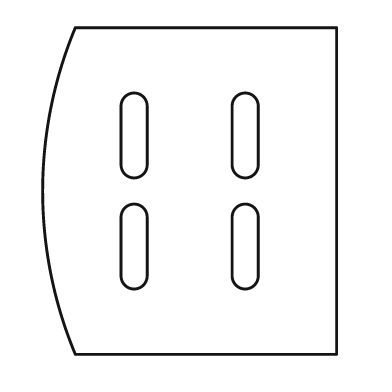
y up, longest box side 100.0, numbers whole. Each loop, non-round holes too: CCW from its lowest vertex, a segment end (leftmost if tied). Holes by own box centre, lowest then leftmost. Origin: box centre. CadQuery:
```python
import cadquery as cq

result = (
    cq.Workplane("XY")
    .moveTo(-35.0, -50.0)
    .lineTo(45.0, -50.0)
    .lineTo(45.0, 50.0)
    .lineTo(-35.0, 50.0)
    .threePointArc((-45.0, 0.0), (-35.0, -50.0))
    .close()
    .moveTo(-21.0, -26.0)
    .threePointArc((-17.0, -30.0), (-13.0, -26.0))
    .lineTo(-13.0, -8.0)
    .threePointArc((-17.0, -4.0), (-21.0, -8.0))
    .close()
    .moveTo(13.0, -26.0)
    .threePointArc((17.0, -30.0), (21.0, -26.0))
    .lineTo(21.0, -8.0)
    .threePointArc((17.0, -4.0), (13.0, -8.0))
    .close()
    .moveTo(-21.0, 8.0)
    .threePointArc((-17.0, 4.0), (-13.0, 8.0))
    .lineTo(-13.0, 26.0)
    .threePointArc((-17.0, 30.0), (-21.0, 26.0))
    .close()
    .moveTo(13.0, 8.0)
    .threePointArc((17.0, 4.0), (21.0, 8.0))
    .lineTo(21.0, 26.0)
    .threePointArc((17.0, 30.0), (13.0, 26.0))
    .close()
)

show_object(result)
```